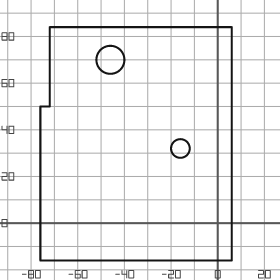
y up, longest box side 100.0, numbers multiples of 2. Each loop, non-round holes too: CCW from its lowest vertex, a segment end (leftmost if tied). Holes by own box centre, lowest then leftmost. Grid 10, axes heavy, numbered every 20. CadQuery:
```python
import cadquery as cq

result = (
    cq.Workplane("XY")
    .moveTo(-76.0, -16.0)
    .lineTo(6.0, -16.0)
    .lineTo(6.0, 84.0)
    .lineTo(-72.0, 84.0)
    .lineTo(-72.0, 50.0)
    .lineTo(-76.0, 50.0)
    .close()
    .moveTo(-16.0, 32.0)
    .circle(4.0)
    .moveTo(-46.0, 70.0)
    .circle(6.0)
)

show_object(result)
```